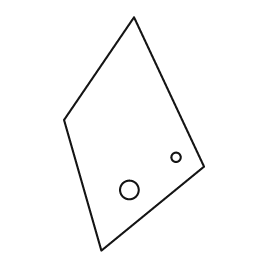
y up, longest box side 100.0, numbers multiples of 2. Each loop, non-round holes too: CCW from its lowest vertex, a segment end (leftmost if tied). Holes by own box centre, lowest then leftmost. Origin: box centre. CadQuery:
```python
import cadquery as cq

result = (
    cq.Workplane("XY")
    .moveTo(-14.0, -50.0)
    .lineTo(30.0, -14.0)
    .lineTo(0.0, 50.0)
    .lineTo(-30.0, 6.0)
    .close()
    .moveTo(-2.0, -24.0)
    .circle(4.0)
    .moveTo(18.0, -10.0)
    .circle(2.0)
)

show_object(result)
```